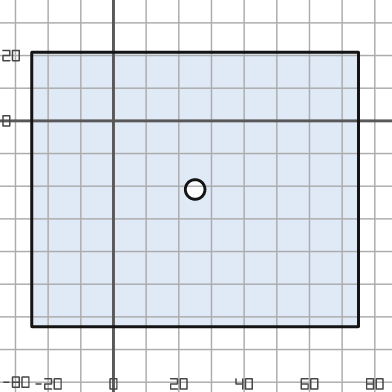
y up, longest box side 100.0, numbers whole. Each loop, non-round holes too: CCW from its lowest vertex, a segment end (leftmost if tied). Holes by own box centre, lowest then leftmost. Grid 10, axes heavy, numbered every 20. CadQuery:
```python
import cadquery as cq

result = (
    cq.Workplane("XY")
    .moveTo(-25.0, -63.0)
    .lineTo(75.0, -63.0)
    .lineTo(75.0, 21.0)
    .lineTo(-25.0, 21.0)
    .close()
    .moveTo(25.0, -21.0)
    .circle(3.0)
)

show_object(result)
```